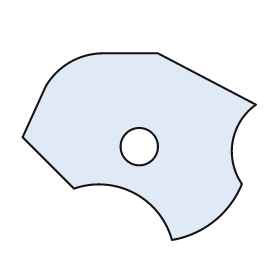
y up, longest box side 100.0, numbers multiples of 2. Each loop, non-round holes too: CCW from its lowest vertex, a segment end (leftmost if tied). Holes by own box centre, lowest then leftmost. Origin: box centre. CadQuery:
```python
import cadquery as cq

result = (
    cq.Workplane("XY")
    .moveTo(14.0, -40.0)
    .threePointArc((32.0, -32.0), (44.0, -16.0))
    .threePointArc((40.0, 2.0), (50.0, 18.0))
    .lineTo(8.0, 40.0)
    .lineTo(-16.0, 40.0)
    .threePointArc((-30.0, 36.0), (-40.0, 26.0))
    .lineTo(-50.0, 4.0)
    .lineTo(-28.0, -18.0)
    .threePointArc((-2.0, -20.0), (14.0, -40.0))
    .close()
    .moveTo(0.0, 0.0)
    .circle(8.0)
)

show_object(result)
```